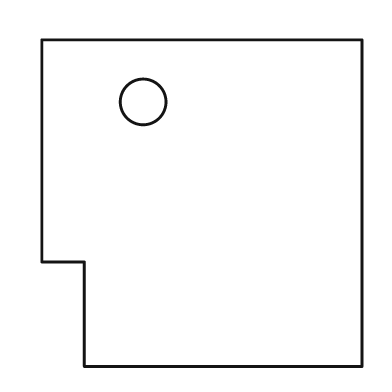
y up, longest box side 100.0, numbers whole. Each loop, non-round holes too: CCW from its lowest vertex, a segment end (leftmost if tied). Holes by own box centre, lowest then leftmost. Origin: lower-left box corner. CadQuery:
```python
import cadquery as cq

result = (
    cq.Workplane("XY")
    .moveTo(13.0, 0.0)
    .lineTo(98.0, 0.0)
    .lineTo(98.0, 100.0)
    .lineTo(0.0, 100.0)
    .lineTo(0.0, 32.0)
    .lineTo(13.0, 32.0)
    .close()
    .moveTo(31.0, 81.0)
    .circle(7.0)
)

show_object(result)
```